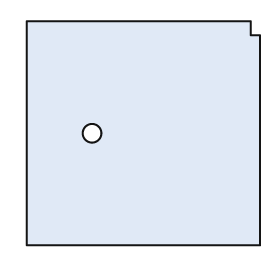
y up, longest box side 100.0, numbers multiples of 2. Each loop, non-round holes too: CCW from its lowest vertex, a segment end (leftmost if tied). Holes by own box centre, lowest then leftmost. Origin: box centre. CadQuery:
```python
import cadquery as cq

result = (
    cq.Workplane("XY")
    .moveTo(-50.0, -48.0)
    .lineTo(50.0, -48.0)
    .lineTo(50.0, 42.0)
    .lineTo(46.0, 42.0)
    .lineTo(46.0, 48.0)
    .lineTo(-50.0, 48.0)
    .close()
    .moveTo(-22.0, 0.0)
    .circle(4.0)
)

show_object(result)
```